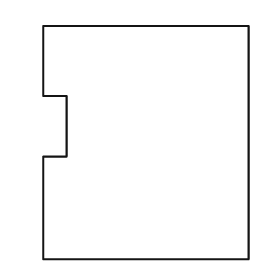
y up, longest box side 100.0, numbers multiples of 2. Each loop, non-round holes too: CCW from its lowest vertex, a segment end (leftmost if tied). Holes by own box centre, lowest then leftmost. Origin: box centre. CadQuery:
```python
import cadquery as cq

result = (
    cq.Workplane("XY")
    .moveTo(-44.0, -50.0)
    .lineTo(44.0, -50.0)
    .lineTo(44.0, 50.0)
    .lineTo(-44.0, 50.0)
    .lineTo(-44.0, 20.0)
    .lineTo(-34.0, 20.0)
    .lineTo(-34.0, -6.0)
    .lineTo(-44.0, -6.0)
    .close()
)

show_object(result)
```